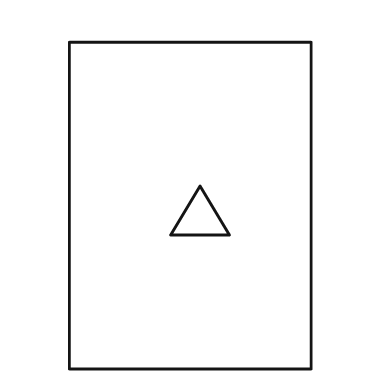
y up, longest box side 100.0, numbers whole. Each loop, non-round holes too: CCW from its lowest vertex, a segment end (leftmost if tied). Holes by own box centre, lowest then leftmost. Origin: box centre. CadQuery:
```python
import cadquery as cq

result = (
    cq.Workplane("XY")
    .moveTo(-37.0, -50.0)
    .lineTo(37.0, -50.0)
    .lineTo(37.0, 50.0)
    .lineTo(-37.0, 50.0)
    .close()
    .moveTo(-6.0, -9.0)
    .lineTo(12.0, -9.0)
    .lineTo(3.0, 6.0)
    .close()
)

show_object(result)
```